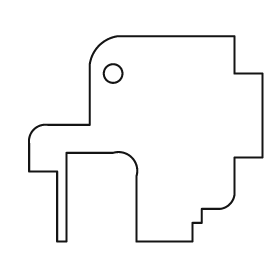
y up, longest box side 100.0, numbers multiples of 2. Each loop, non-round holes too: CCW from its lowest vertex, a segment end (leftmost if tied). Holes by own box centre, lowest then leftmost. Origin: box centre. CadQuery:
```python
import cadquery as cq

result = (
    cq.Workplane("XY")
    .moveTo(-38.0, -44.0)
    .lineTo(-34.0, -44.0)
    .lineTo(-34.0, -6.0)
    .lineTo(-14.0, -6.0)
    .threePointArc((-6.0, -8.0), (-4.0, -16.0))
    .lineTo(-4.0, -44.0)
    .lineTo(20.0, -44.0)
    .lineTo(20.0, -36.0)
    .lineTo(24.0, -36.0)
    .lineTo(24.0, -30.0)
    .lineTo(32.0, -30.0)
    .threePointArc((36.0, -28.0), (38.0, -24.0))
    .lineTo(38.0, -8.0)
    .lineTo(50.0, -8.0)
    .lineTo(50.0, 28.0)
    .lineTo(38.0, 28.0)
    .lineTo(38.0, 44.0)
    .lineTo(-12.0, 44.0)
    .threePointArc((-20.0, 40.0), (-24.0, 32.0))
    .lineTo(-24.0, 6.0)
    .lineTo(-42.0, 6.0)
    .threePointArc((-48.0, 4.0), (-50.0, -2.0))
    .lineTo(-50.0, -14.0)
    .lineTo(-38.0, -14.0)
    .close()
    .moveTo(-14.0, 28.0)
    .circle(4.0)
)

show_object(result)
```